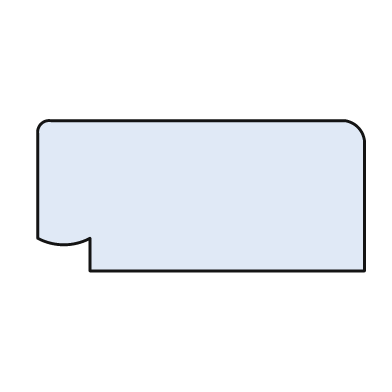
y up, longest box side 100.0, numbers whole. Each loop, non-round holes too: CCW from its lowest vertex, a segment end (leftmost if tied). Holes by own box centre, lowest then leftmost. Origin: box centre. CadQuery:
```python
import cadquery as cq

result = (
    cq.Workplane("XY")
    .moveTo(-34.0, -23.0)
    .lineTo(50.0, -23.0)
    .lineTo(50.0, 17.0)
    .threePointArc((48.0, 21.0), (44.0, 23.0))
    .lineTo(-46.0, 23.0)
    .threePointArc((-49.0, 22.0), (-50.0, 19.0))
    .lineTo(-50.0, -13.0)
    .threePointArc((-42.0, -15.0), (-34.0, -13.0))
    .close()
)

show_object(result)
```